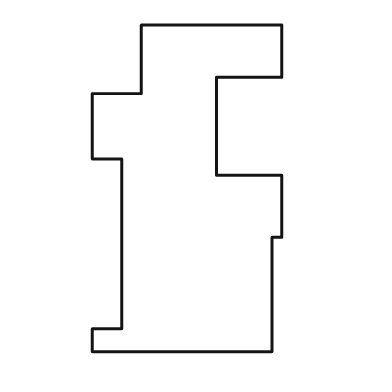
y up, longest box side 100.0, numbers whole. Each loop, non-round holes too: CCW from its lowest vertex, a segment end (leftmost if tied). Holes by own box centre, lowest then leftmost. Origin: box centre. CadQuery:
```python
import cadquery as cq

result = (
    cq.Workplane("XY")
    .moveTo(-29.0, -50.0)
    .lineTo(26.0, -50.0)
    .lineTo(26.0, -15.0)
    .lineTo(29.0, -15.0)
    .lineTo(29.0, 4.0)
    .lineTo(9.0, 4.0)
    .lineTo(9.0, 34.0)
    .lineTo(29.0, 34.0)
    .lineTo(29.0, 50.0)
    .lineTo(-14.0, 50.0)
    .lineTo(-14.0, 29.0)
    .lineTo(-29.0, 29.0)
    .lineTo(-29.0, 9.0)
    .lineTo(-20.0, 9.0)
    .lineTo(-20.0, -43.0)
    .lineTo(-29.0, -43.0)
    .close()
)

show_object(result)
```